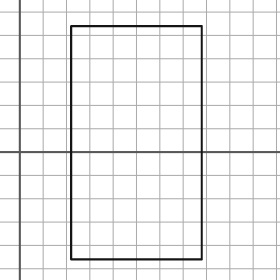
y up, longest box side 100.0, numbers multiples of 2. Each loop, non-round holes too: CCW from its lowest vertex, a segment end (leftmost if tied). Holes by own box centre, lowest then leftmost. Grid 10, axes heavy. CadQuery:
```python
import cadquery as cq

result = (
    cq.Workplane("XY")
    .moveTo(22.0, -46.0)
    .lineTo(78.0, -46.0)
    .lineTo(78.0, 54.0)
    .lineTo(22.0, 54.0)
    .close()
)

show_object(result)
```